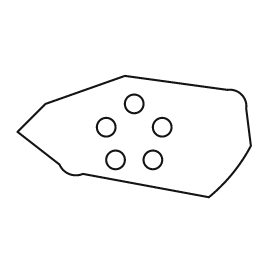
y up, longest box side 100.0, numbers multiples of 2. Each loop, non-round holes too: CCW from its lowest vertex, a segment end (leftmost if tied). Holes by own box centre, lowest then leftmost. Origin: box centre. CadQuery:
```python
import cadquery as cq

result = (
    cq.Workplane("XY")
    .moveTo(32.0, -26.0)
    .threePointArc((42.0, -16.0), (50.0, -4.0))
    .lineTo(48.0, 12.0)
    .threePointArc((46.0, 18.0), (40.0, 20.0))
    .lineTo(-4.0, 26.0)
    .lineTo(-38.0, 14.0)
    .lineTo(-50.0, 2.0)
    .lineTo(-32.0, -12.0)
    .threePointArc((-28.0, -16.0), (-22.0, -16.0))
    .close()
    .moveTo(-8.0, -10.0)
    .circle(4.0)
    .moveTo(8.0, -10.0)
    .circle(4.0)
    .moveTo(-12.0, 4.0)
    .circle(4.0)
    .moveTo(12.0, 4.0)
    .circle(4.0)
    .moveTo(0.0, 14.0)
    .circle(4.0)
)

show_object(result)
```